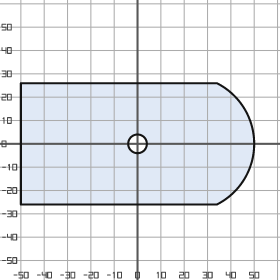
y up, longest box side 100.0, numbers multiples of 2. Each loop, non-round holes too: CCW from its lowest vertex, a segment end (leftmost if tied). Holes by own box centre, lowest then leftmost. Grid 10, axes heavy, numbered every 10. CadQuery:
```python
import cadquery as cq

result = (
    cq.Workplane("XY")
    .moveTo(-50.0, -26.0)
    .lineTo(34.0, -26.0)
    .threePointArc((50.0, 0.0), (34.0, 26.0))
    .lineTo(-50.0, 26.0)
    .close()
    .moveTo(0.0, 0.0)
    .circle(4.0)
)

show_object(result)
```